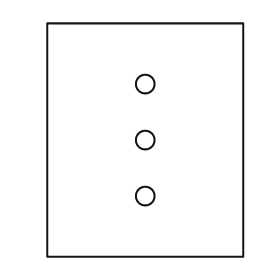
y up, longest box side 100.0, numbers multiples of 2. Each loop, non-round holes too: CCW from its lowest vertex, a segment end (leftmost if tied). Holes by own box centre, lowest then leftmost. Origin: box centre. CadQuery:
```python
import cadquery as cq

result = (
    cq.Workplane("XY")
    .moveTo(-42.0, -50.0)
    .lineTo(42.0, -50.0)
    .lineTo(42.0, 50.0)
    .lineTo(-42.0, 50.0)
    .close()
    .moveTo(0.0, -24.0)
    .circle(4.0)
    .moveTo(0.0, 0.0)
    .circle(4.0)
    .moveTo(0.0, 24.0)
    .circle(4.0)
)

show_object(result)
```